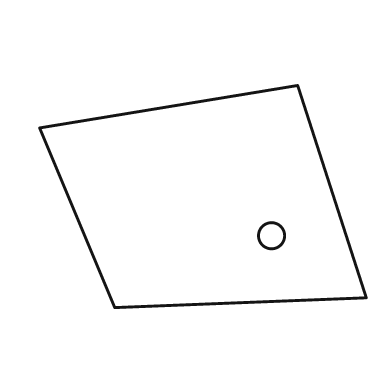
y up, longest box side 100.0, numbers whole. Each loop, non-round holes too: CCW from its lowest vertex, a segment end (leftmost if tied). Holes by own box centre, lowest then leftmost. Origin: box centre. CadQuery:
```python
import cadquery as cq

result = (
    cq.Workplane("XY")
    .moveTo(-27.0, -34.0)
    .lineTo(50.0, -31.0)
    .lineTo(29.0, 34.0)
    .lineTo(-50.0, 21.0)
    .close()
    .moveTo(21.0, -12.0)
    .circle(4.0)
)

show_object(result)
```